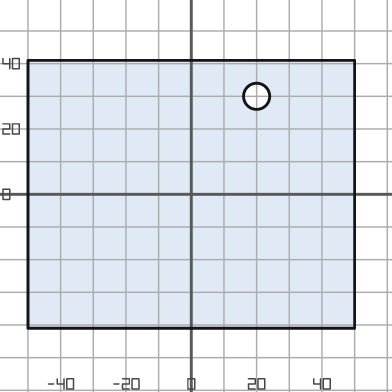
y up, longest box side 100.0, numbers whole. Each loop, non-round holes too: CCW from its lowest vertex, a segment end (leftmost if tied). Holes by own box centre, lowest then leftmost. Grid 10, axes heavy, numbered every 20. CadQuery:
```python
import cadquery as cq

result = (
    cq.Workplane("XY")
    .moveTo(-50.0, -41.0)
    .lineTo(50.0, -41.0)
    .lineTo(50.0, 41.0)
    .lineTo(-50.0, 41.0)
    .close()
    .moveTo(20.0, 30.0)
    .circle(4.0)
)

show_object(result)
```